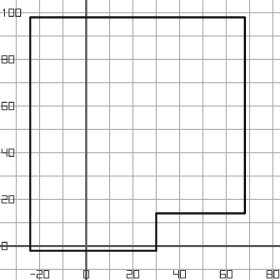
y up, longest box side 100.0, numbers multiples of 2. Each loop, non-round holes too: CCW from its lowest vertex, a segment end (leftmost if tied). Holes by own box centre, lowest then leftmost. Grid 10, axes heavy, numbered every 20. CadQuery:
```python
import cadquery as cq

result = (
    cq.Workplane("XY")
    .moveTo(-24.0, -2.0)
    .lineTo(30.0, -2.0)
    .lineTo(30.0, 14.0)
    .lineTo(68.0, 14.0)
    .lineTo(68.0, 98.0)
    .lineTo(-24.0, 98.0)
    .close()
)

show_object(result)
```